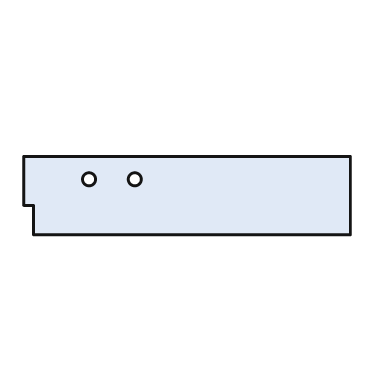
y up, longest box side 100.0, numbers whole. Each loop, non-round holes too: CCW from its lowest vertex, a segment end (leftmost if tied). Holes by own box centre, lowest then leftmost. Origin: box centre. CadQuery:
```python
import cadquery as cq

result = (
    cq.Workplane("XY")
    .moveTo(-47.0, -12.0)
    .lineTo(50.0, -12.0)
    .lineTo(50.0, 12.0)
    .lineTo(-50.0, 12.0)
    .lineTo(-50.0, -3.0)
    .lineTo(-47.0, -3.0)
    .close()
    .moveTo(-30.0, 5.0)
    .circle(2.0)
    .moveTo(-16.0, 5.0)
    .circle(2.0)
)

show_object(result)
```